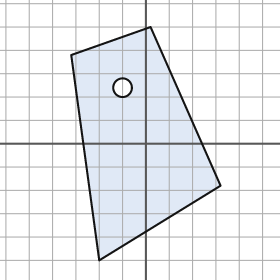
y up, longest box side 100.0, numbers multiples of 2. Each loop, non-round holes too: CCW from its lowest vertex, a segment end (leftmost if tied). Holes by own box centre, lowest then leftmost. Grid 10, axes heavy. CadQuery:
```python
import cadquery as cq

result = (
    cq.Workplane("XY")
    .moveTo(-20.0, -50.0)
    .lineTo(32.0, -18.0)
    .lineTo(2.0, 50.0)
    .lineTo(-32.0, 38.0)
    .close()
    .moveTo(-10.0, 24.0)
    .circle(4.0)
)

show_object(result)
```